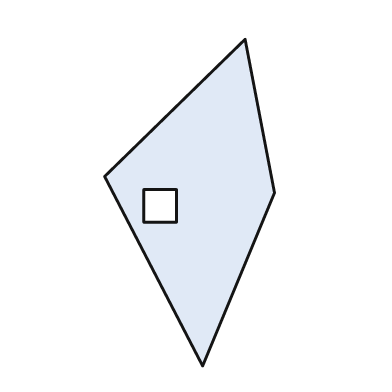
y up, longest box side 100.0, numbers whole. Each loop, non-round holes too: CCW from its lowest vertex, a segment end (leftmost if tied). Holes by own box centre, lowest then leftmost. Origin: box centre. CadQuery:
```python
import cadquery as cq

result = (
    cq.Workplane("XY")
    .moveTo(4.0, -50.0)
    .lineTo(26.0, 3.0)
    .lineTo(17.0, 50.0)
    .lineTo(-26.0, 8.0)
    .close()
    .moveTo(-14.0, -6.0)
    .lineTo(-4.0, -6.0)
    .lineTo(-4.0, 4.0)
    .lineTo(-14.0, 4.0)
    .close()
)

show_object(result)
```